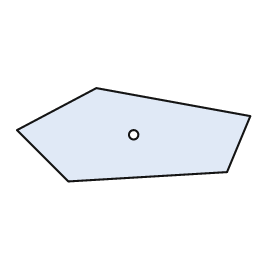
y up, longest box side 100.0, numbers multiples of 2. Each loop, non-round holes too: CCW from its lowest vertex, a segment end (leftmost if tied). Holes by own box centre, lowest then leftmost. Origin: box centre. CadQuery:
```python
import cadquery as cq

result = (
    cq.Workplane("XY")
    .moveTo(-28.0, -20.0)
    .lineTo(40.0, -16.0)
    .lineTo(50.0, 8.0)
    .lineTo(-16.0, 20.0)
    .lineTo(-50.0, 2.0)
    .close()
    .moveTo(0.0, 0.0)
    .circle(2.0)
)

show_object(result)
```